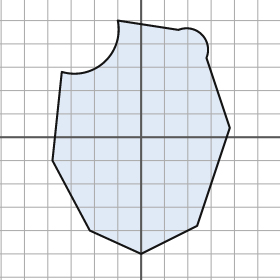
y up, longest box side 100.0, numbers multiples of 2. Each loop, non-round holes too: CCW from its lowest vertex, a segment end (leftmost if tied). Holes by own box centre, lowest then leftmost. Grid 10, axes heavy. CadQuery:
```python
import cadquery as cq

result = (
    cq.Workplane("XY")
    .moveTo(0.0, -50.0)
    .lineTo(24.0, -38.0)
    .lineTo(38.0, 4.0)
    .lineTo(28.0, 34.0)
    .threePointArc((26.0, 44.0), (16.0, 46.0))
    .lineTo(-10.0, 50.0)
    .threePointArc((-16.0, 32.0), (-34.0, 28.0))
    .lineTo(-38.0, -10.0)
    .lineTo(-22.0, -40.0)
    .close()
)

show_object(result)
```